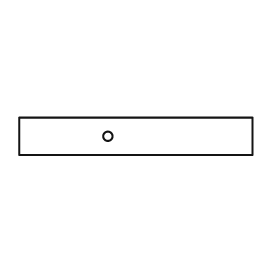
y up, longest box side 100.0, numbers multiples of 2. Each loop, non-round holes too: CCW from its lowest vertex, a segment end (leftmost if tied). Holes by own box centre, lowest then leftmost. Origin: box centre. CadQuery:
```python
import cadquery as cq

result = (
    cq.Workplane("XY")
    .moveTo(-50.0, -8.0)
    .lineTo(50.0, -8.0)
    .lineTo(50.0, 8.0)
    .lineTo(-50.0, 8.0)
    .close()
    .moveTo(-12.0, 0.0)
    .circle(2.0)
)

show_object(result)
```